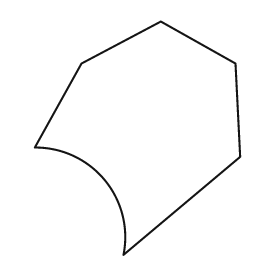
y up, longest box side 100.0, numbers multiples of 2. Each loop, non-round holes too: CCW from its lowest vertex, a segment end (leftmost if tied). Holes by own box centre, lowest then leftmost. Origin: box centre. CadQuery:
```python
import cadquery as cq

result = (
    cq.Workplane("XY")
    .moveTo(-6.0, -50.0)
    .lineTo(44.0, -8.0)
    .lineTo(42.0, 32.0)
    .lineTo(10.0, 50.0)
    .lineTo(-24.0, 32.0)
    .lineTo(-44.0, -4.0)
    .threePointArc((-14.0, -18.0), (-6.0, -50.0))
    .close()
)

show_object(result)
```